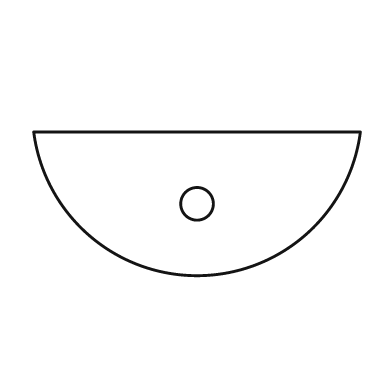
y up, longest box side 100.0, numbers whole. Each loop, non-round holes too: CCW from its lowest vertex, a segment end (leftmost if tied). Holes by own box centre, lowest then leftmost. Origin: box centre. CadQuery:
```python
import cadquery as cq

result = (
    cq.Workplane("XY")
    .moveTo(-50.0, 22.0)
    .threePointArc((0.0, -22.0), (50.0, 22.0))
    .close()
    .moveTo(0.0, 0.0)
    .circle(5.0)
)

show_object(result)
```